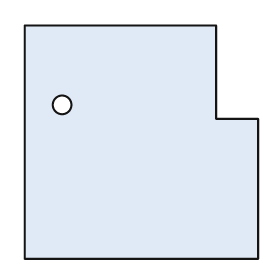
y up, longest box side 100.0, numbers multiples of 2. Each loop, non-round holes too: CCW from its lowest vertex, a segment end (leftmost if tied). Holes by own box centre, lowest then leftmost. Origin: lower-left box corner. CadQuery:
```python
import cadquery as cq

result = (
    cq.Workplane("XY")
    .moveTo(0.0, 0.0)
    .lineTo(100.0, 0.0)
    .lineTo(100.0, 60.0)
    .lineTo(82.0, 60.0)
    .lineTo(82.0, 100.0)
    .lineTo(0.0, 100.0)
    .close()
    .moveTo(16.0, 66.0)
    .circle(4.0)
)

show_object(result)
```